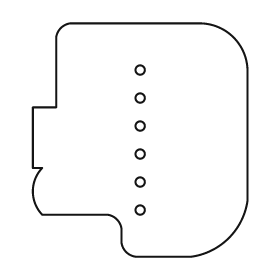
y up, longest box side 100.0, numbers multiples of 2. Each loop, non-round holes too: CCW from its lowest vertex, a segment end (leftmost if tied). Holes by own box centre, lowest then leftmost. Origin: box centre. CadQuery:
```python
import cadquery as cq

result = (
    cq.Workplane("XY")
    .moveTo(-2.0, -50.0)
    .lineTo(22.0, -50.0)
    .threePointArc((38.0, -42.0), (46.0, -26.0))
    .lineTo(46.0, 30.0)
    .threePointArc((40.0, 44.0), (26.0, 50.0))
    .lineTo(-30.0, 50.0)
    .threePointArc((-34.0, 48.0), (-36.0, 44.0))
    .lineTo(-36.0, 14.0)
    .lineTo(-46.0, 14.0)
    .lineTo(-46.0, -12.0)
    .lineTo(-42.0, -12.0)
    .threePointArc((-46.0, -22.0), (-42.0, -32.0))
    .lineTo(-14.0, -32.0)
    .threePointArc((-10.0, -34.0), (-8.0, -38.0))
    .lineTo(-8.0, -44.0)
    .threePointArc((-6.0, -48.0), (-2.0, -50.0))
    .close()
    .moveTo(0.0, -30.0)
    .circle(2.0)
    .moveTo(0.0, -18.0)
    .circle(2.0)
    .moveTo(0.0, -6.0)
    .circle(2.0)
    .moveTo(0.0, 6.0)
    .circle(2.0)
    .moveTo(0.0, 18.0)
    .circle(2.0)
    .moveTo(0.0, 30.0)
    .circle(2.0)
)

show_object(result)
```